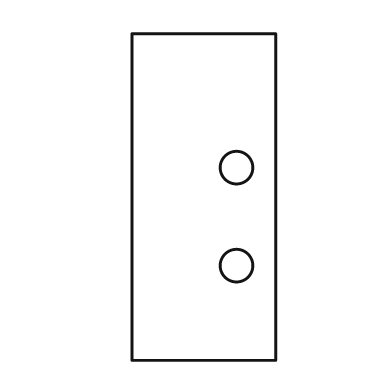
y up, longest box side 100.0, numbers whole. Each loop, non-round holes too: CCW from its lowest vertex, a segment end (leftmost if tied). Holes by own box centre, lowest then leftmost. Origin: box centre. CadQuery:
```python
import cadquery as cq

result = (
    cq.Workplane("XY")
    .moveTo(-22.0, -50.0)
    .lineTo(22.0, -50.0)
    .lineTo(22.0, 50.0)
    .lineTo(-22.0, 50.0)
    .close()
    .moveTo(10.0, -21.0)
    .circle(5.0)
    .moveTo(10.0, 9.0)
    .circle(5.0)
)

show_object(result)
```